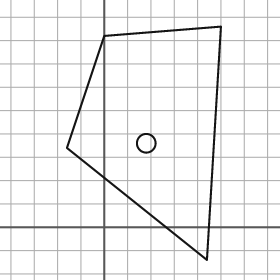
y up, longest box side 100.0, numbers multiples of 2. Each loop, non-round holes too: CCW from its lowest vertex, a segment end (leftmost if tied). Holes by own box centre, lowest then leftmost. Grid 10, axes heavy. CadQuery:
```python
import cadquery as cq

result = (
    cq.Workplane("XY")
    .moveTo(44.0, -14.0)
    .lineTo(50.0, 86.0)
    .lineTo(0.0, 82.0)
    .lineTo(-16.0, 34.0)
    .close()
    .moveTo(18.0, 36.0)
    .circle(4.0)
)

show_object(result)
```